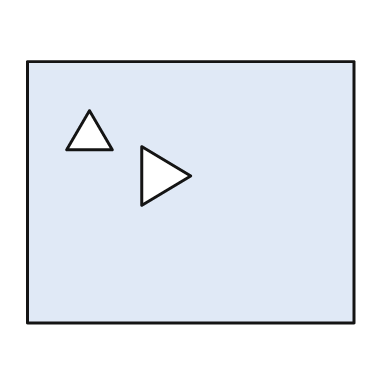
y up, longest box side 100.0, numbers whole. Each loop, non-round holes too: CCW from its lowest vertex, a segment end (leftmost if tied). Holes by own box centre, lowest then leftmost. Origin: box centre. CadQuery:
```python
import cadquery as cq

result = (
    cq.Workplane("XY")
    .moveTo(-50.0, -40.0)
    .lineTo(50.0, -40.0)
    .lineTo(50.0, 40.0)
    .lineTo(-50.0, 40.0)
    .close()
    .moveTo(-15.0, -4.0)
    .lineTo(0.0, 5.0)
    .lineTo(-15.0, 14.0)
    .close()
    .moveTo(-38.0, 13.0)
    .lineTo(-24.0, 13.0)
    .lineTo(-31.0, 25.0)
    .close()
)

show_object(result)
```